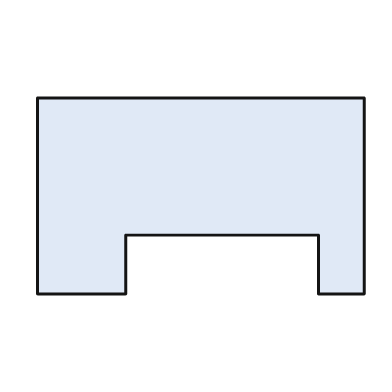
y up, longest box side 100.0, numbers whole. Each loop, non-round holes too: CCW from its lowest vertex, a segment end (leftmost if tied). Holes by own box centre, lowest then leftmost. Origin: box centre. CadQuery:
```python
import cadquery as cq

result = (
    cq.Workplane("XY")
    .moveTo(-50.0, -30.0)
    .lineTo(-23.0, -30.0)
    .lineTo(-23.0, -12.0)
    .lineTo(36.0, -12.0)
    .lineTo(36.0, -30.0)
    .lineTo(50.0, -30.0)
    .lineTo(50.0, 30.0)
    .lineTo(-50.0, 30.0)
    .close()
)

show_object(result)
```